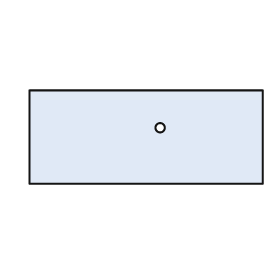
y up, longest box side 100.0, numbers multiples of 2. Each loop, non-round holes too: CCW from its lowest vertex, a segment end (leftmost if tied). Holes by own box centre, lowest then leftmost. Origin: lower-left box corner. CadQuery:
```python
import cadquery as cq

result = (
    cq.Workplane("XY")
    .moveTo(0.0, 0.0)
    .lineTo(100.0, 0.0)
    .lineTo(100.0, 40.0)
    .lineTo(0.0, 40.0)
    .close()
    .moveTo(56.0, 24.0)
    .circle(2.0)
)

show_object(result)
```